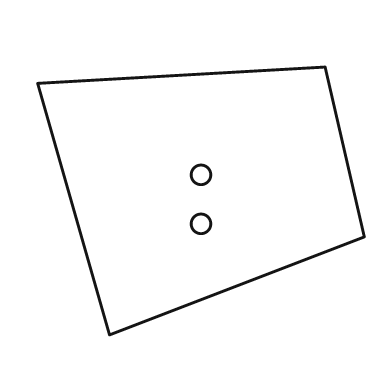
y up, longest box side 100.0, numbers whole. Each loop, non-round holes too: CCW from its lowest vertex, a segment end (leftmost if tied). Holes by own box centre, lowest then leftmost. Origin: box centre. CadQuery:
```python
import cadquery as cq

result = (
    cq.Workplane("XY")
    .moveTo(-28.0, -41.0)
    .lineTo(50.0, -11.0)
    .lineTo(38.0, 41.0)
    .lineTo(-50.0, 36.0)
    .close()
    .moveTo(0.0, -7.0)
    .circle(3.0)
    .moveTo(0.0, 8.0)
    .circle(3.0)
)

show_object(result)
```